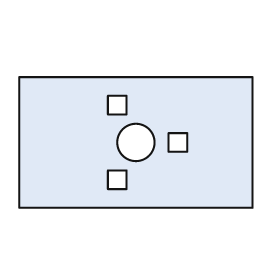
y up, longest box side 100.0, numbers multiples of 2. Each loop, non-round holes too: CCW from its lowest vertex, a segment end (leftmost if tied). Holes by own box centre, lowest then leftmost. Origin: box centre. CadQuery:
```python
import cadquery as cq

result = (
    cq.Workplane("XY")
    .moveTo(-50.0, -28.0)
    .lineTo(50.0, -28.0)
    .lineTo(50.0, 28.0)
    .lineTo(-50.0, 28.0)
    .close()
    .moveTo(-12.0, -20.0)
    .lineTo(-4.0, -20.0)
    .lineTo(-4.0, -12.0)
    .lineTo(-12.0, -12.0)
    .close()
    .moveTo(0.0, 0.0)
    .circle(8.0)
    .moveTo(14.0, -4.0)
    .lineTo(22.0, -4.0)
    .lineTo(22.0, 4.0)
    .lineTo(14.0, 4.0)
    .close()
    .moveTo(-12.0, 12.0)
    .lineTo(-4.0, 12.0)
    .lineTo(-4.0, 20.0)
    .lineTo(-12.0, 20.0)
    .close()
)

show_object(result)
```